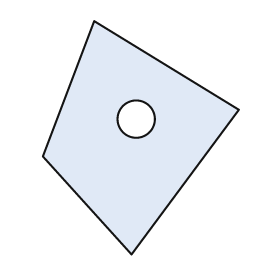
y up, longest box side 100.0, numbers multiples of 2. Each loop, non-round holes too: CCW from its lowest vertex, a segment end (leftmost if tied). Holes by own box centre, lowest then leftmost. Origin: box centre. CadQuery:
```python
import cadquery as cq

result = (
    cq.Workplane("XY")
    .moveTo(-4.0, -50.0)
    .lineTo(42.0, 12.0)
    .lineTo(-20.0, 50.0)
    .lineTo(-42.0, -8.0)
    .close()
    .moveTo(-2.0, 8.0)
    .circle(8.0)
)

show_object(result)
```